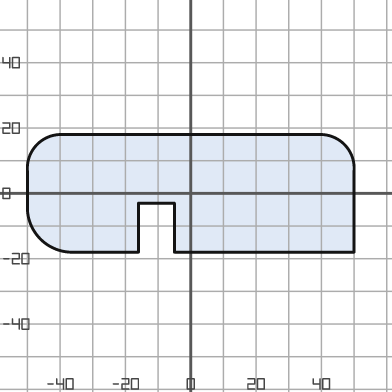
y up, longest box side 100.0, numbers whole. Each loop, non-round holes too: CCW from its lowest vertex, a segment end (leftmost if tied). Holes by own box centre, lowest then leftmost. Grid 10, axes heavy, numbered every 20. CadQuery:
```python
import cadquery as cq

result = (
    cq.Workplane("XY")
    .moveTo(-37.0, -18.0)
    .lineTo(-16.0, -18.0)
    .lineTo(-16.0, -3.0)
    .lineTo(-5.0, -3.0)
    .lineTo(-5.0, -18.0)
    .lineTo(50.0, -18.0)
    .lineTo(50.0, 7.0)
    .threePointArc((47.0, 15.0), (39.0, 18.0))
    .lineTo(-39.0, 18.0)
    .threePointArc((-47.0, 15.0), (-50.0, 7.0))
    .lineTo(-50.0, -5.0)
    .threePointArc((-46.0, -14.0), (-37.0, -18.0))
    .close()
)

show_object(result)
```